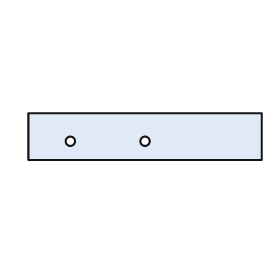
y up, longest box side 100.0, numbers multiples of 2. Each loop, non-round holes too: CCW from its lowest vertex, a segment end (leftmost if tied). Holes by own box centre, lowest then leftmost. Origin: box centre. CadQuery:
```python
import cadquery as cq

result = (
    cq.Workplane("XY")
    .moveTo(-50.0, -10.0)
    .lineTo(50.0, -10.0)
    .lineTo(50.0, 10.0)
    .lineTo(-50.0, 10.0)
    .close()
    .moveTo(-32.0, -2.0)
    .circle(2.0)
    .moveTo(0.0, -2.0)
    .circle(2.0)
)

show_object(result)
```